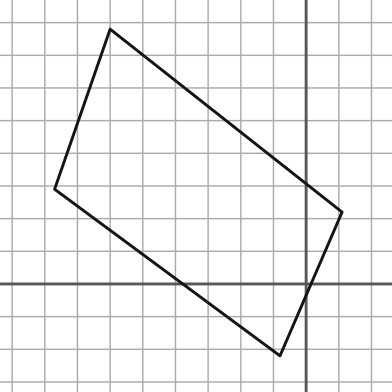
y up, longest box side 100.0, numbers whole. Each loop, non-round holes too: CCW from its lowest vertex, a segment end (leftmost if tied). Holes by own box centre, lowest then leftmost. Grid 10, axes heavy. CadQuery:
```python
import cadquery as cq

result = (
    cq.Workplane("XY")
    .moveTo(-8.0, -22.0)
    .lineTo(11.0, 22.0)
    .lineTo(-60.0, 78.0)
    .lineTo(-77.0, 29.0)
    .close()
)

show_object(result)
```